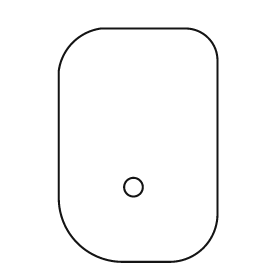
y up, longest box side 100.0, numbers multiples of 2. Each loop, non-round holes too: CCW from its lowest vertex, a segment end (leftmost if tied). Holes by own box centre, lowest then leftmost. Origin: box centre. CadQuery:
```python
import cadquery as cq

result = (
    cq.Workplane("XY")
    .moveTo(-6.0, -50.0)
    .lineTo(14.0, -50.0)
    .threePointArc((28.0, -44.0), (34.0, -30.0))
    .lineTo(34.0, 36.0)
    .threePointArc((30.0, 46.0), (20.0, 50.0))
    .lineTo(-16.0, 50.0)
    .threePointArc((-28.0, 44.0), (-34.0, 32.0))
    .lineTo(-34.0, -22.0)
    .threePointArc((-26.0, -42.0), (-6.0, -50.0))
    .close()
    .moveTo(-2.0, -18.0)
    .circle(4.0)
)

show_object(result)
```